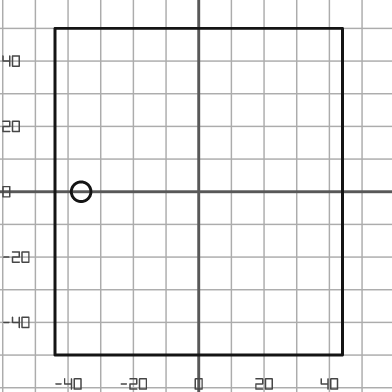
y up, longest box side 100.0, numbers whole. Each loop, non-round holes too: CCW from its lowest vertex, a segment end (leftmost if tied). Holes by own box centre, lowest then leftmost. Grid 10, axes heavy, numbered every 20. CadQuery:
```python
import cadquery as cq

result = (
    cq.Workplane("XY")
    .moveTo(-44.0, -50.0)
    .lineTo(44.0, -50.0)
    .lineTo(44.0, 50.0)
    .lineTo(-44.0, 50.0)
    .close()
    .moveTo(-36.0, 0.0)
    .circle(3.0)
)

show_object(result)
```